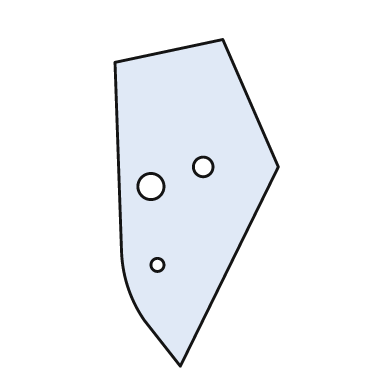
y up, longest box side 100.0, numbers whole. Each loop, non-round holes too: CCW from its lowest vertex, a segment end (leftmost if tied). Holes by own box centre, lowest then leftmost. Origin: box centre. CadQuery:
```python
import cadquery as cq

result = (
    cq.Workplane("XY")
    .moveTo(-5.0, -50.0)
    .lineTo(25.0, 11.0)
    .lineTo(8.0, 50.0)
    .lineTo(-25.0, 43.0)
    .lineTo(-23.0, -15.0)
    .threePointArc((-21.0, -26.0), (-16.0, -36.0))
    .close()
    .moveTo(-12.0, -19.0)
    .circle(2.0)
    .moveTo(-14.0, 5.0)
    .circle(4.0)
    .moveTo(2.0, 11.0)
    .circle(3.0)
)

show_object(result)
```